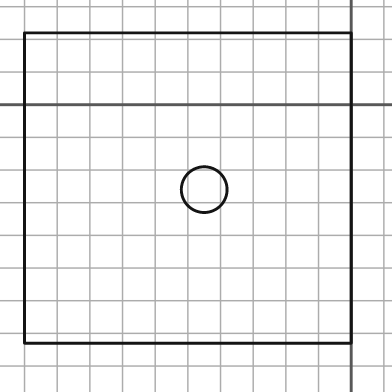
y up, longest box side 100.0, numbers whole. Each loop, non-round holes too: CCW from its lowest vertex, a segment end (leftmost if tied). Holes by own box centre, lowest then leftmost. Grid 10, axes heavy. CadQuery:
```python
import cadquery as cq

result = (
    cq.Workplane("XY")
    .moveTo(-100.0, -73.0)
    .lineTo(0.0, -73.0)
    .lineTo(0.0, 22.0)
    .lineTo(-100.0, 22.0)
    .close()
    .moveTo(-45.0, -26.0)
    .circle(7.0)
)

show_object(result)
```